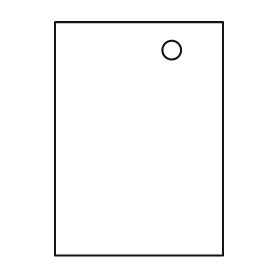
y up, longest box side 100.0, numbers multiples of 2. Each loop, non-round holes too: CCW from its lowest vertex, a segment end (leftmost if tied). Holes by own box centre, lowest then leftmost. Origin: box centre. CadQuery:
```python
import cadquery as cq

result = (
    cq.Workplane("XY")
    .moveTo(-36.0, -50.0)
    .lineTo(36.0, -50.0)
    .lineTo(36.0, 50.0)
    .lineTo(-36.0, 50.0)
    .close()
    .moveTo(14.0, 38.0)
    .circle(4.0)
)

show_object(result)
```